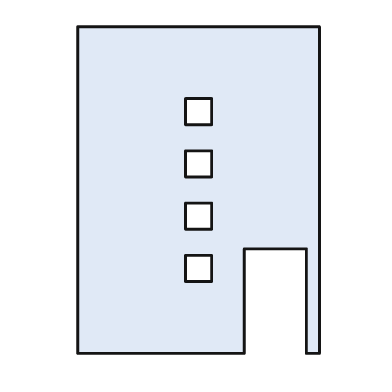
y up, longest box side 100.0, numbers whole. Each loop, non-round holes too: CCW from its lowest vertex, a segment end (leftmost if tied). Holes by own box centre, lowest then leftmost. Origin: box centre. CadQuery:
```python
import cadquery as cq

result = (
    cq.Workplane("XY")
    .moveTo(-37.0, -50.0)
    .lineTo(14.0, -50.0)
    .lineTo(14.0, -18.0)
    .lineTo(33.0, -18.0)
    .lineTo(33.0, -50.0)
    .lineTo(37.0, -50.0)
    .lineTo(37.0, 50.0)
    .lineTo(-37.0, 50.0)
    .close()
    .moveTo(-4.0, -28.0)
    .lineTo(4.0, -28.0)
    .lineTo(4.0, -20.0)
    .lineTo(-4.0, -20.0)
    .close()
    .moveTo(-4.0, -12.0)
    .lineTo(4.0, -12.0)
    .lineTo(4.0, -4.0)
    .lineTo(-4.0, -4.0)
    .close()
    .moveTo(-4.0, 4.0)
    .lineTo(4.0, 4.0)
    .lineTo(4.0, 12.0)
    .lineTo(-4.0, 12.0)
    .close()
    .moveTo(-4.0, 20.0)
    .lineTo(4.0, 20.0)
    .lineTo(4.0, 28.0)
    .lineTo(-4.0, 28.0)
    .close()
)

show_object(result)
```